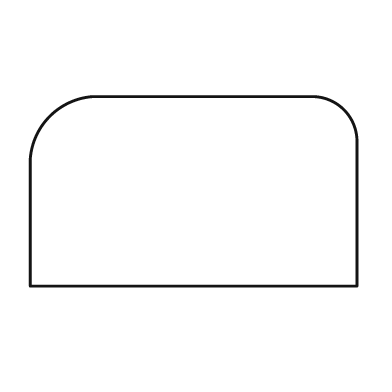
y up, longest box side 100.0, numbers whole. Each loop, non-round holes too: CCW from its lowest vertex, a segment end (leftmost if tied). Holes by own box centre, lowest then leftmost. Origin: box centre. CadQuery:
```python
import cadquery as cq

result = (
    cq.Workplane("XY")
    .moveTo(-50.0, -29.0)
    .lineTo(50.0, -29.0)
    .lineTo(50.0, 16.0)
    .threePointArc((46.0, 25.0), (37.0, 29.0))
    .lineTo(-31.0, 29.0)
    .threePointArc((-44.0, 23.0), (-50.0, 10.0))
    .close()
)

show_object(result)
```